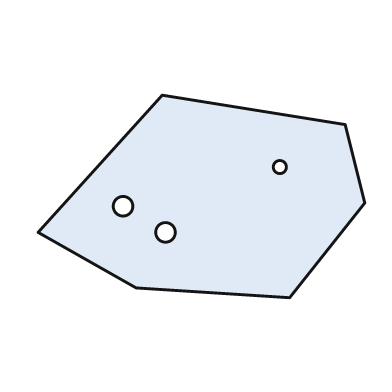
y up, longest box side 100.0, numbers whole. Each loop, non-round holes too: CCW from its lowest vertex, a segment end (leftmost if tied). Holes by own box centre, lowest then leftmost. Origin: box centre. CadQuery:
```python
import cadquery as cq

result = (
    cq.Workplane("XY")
    .moveTo(27.0, -31.0)
    .lineTo(50.0, -2.0)
    .lineTo(44.0, 22.0)
    .lineTo(-12.0, 31.0)
    .lineTo(-50.0, -11.0)
    .lineTo(-20.0, -28.0)
    .close()
    .moveTo(-11.0, -11.0)
    .circle(3.0)
    .moveTo(-24.0, -3.0)
    .circle(3.0)
    .moveTo(24.0, 9.0)
    .circle(2.0)
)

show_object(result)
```